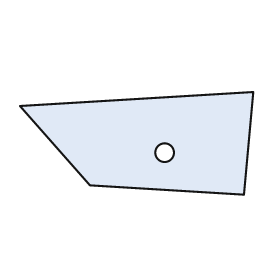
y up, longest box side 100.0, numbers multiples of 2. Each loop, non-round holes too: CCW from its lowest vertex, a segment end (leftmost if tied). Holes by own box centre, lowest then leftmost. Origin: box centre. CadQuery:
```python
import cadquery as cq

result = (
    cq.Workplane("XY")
    .moveTo(46.0, -22.0)
    .lineTo(50.0, 22.0)
    .lineTo(-50.0, 16.0)
    .lineTo(-20.0, -18.0)
    .close()
    .moveTo(12.0, -4.0)
    .circle(4.0)
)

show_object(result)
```